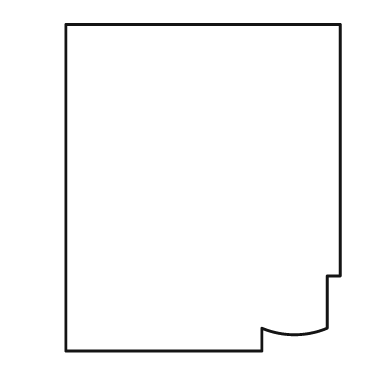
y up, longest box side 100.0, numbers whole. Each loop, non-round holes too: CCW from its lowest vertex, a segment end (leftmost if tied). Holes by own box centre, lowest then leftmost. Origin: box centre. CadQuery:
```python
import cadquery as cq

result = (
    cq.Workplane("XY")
    .moveTo(-42.0, -50.0)
    .lineTo(18.0, -50.0)
    .lineTo(18.0, -43.0)
    .threePointArc((28.0, -45.0), (38.0, -43.0))
    .lineTo(38.0, -27.0)
    .lineTo(42.0, -27.0)
    .lineTo(42.0, 50.0)
    .lineTo(-42.0, 50.0)
    .close()
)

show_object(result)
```